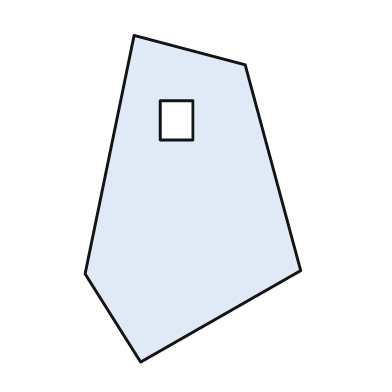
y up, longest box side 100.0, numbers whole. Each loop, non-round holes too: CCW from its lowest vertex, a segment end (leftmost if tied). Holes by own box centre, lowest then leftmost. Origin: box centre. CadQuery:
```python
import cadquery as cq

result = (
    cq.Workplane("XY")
    .moveTo(-16.0, -50.0)
    .lineTo(33.0, -22.0)
    .lineTo(16.0, 41.0)
    .lineTo(-18.0, 50.0)
    .lineTo(-33.0, -23.0)
    .close()
    .moveTo(-10.0, 18.0)
    .lineTo(0.0, 18.0)
    .lineTo(0.0, 30.0)
    .lineTo(-10.0, 30.0)
    .close()
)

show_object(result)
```